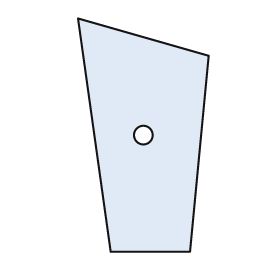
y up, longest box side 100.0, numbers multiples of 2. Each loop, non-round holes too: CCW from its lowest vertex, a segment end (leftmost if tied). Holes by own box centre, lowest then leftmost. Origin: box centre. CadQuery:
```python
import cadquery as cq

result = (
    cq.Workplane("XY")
    .moveTo(-14.0, -50.0)
    .lineTo(20.0, -50.0)
    .lineTo(28.0, 34.0)
    .lineTo(-28.0, 50.0)
    .close()
    .moveTo(0.0, 0.0)
    .circle(4.0)
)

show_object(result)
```